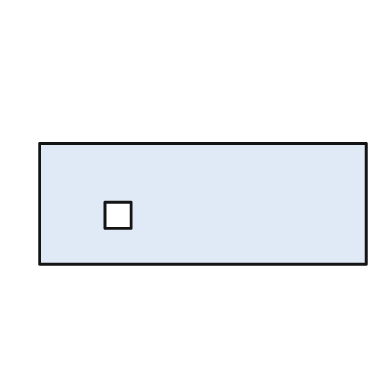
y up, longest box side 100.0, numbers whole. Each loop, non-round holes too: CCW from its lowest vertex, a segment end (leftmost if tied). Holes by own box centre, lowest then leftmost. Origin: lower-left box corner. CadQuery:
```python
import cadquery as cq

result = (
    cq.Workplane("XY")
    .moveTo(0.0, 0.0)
    .lineTo(100.0, 0.0)
    .lineTo(100.0, 37.0)
    .lineTo(0.0, 37.0)
    .close()
    .moveTo(20.0, 11.0)
    .lineTo(28.0, 11.0)
    .lineTo(28.0, 19.0)
    .lineTo(20.0, 19.0)
    .close()
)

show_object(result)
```